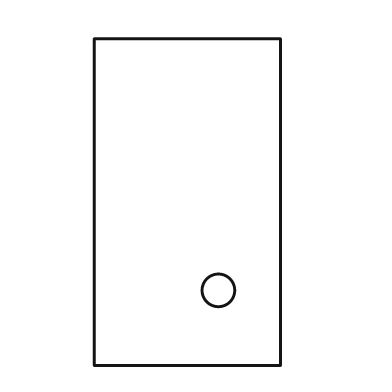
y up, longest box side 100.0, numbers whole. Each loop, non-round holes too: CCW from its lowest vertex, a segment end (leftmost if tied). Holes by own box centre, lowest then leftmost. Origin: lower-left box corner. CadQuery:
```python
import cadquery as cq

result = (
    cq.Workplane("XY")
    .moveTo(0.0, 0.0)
    .lineTo(57.0, 0.0)
    .lineTo(57.0, 100.0)
    .lineTo(0.0, 100.0)
    .close()
    .moveTo(38.0, 23.0)
    .circle(5.0)
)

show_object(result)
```